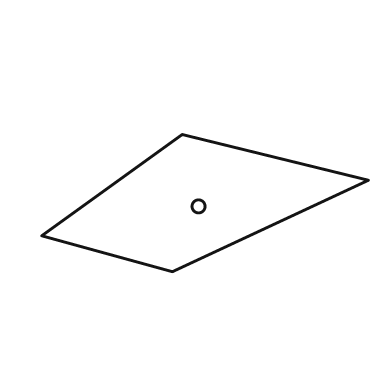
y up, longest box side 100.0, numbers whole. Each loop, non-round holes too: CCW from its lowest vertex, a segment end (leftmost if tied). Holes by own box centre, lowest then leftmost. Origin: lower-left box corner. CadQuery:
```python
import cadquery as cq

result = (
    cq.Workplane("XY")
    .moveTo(40.0, 0.0)
    .lineTo(100.0, 28.0)
    .lineTo(43.0, 42.0)
    .lineTo(0.0, 11.0)
    .close()
    .moveTo(48.0, 20.0)
    .circle(2.0)
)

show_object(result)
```